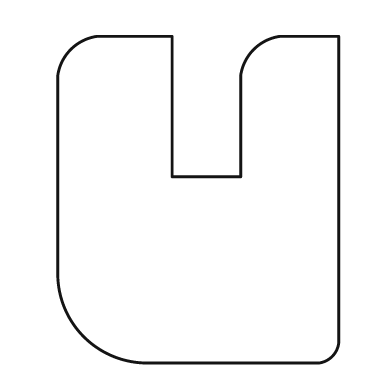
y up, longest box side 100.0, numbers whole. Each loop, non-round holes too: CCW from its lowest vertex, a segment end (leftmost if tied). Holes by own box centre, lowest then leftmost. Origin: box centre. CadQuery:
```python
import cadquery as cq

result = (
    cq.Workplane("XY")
    .moveTo(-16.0, -50.0)
    .lineTo(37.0, -50.0)
    .threePointArc((41.0, -48.0), (43.0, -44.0))
    .lineTo(43.0, 50.0)
    .lineTo(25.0, 50.0)
    .threePointArc((17.0, 46.0), (13.0, 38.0))
    .lineTo(13.0, 7.0)
    .lineTo(-8.0, 7.0)
    .lineTo(-8.0, 50.0)
    .lineTo(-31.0, 50.0)
    .threePointArc((-39.0, 46.0), (-43.0, 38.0))
    .lineTo(-43.0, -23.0)
    .threePointArc((-35.0, -42.0), (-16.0, -50.0))
    .close()
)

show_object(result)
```